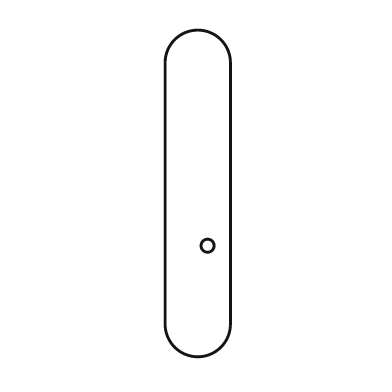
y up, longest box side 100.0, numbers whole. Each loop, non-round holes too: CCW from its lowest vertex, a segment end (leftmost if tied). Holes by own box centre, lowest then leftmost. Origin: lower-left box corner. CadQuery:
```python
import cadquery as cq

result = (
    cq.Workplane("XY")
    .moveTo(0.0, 10.0)
    .threePointArc((10.0, 0.0), (20.0, 10.0))
    .lineTo(20.0, 90.0)
    .threePointArc((10.0, 100.0), (0.0, 90.0))
    .close()
    .moveTo(13.0, 34.0)
    .circle(2.0)
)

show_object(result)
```